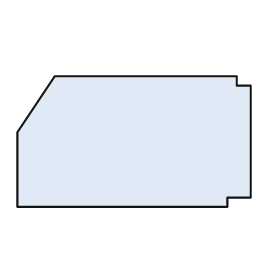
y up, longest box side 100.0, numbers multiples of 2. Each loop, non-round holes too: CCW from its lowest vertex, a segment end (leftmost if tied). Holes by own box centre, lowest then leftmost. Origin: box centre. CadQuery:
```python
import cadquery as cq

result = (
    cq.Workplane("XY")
    .moveTo(-50.0, -28.0)
    .lineTo(40.0, -28.0)
    .lineTo(40.0, -24.0)
    .lineTo(50.0, -24.0)
    .lineTo(50.0, 24.0)
    .lineTo(44.0, 24.0)
    .lineTo(44.0, 28.0)
    .lineTo(-34.0, 28.0)
    .lineTo(-50.0, 4.0)
    .close()
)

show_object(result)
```